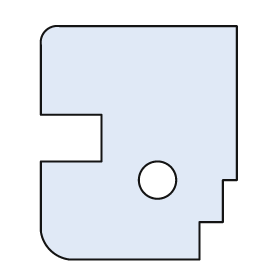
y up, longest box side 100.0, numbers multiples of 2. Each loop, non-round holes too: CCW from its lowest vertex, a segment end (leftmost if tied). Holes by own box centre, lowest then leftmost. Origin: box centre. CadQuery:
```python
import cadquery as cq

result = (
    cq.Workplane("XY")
    .moveTo(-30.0, -50.0)
    .lineTo(26.0, -50.0)
    .lineTo(26.0, -34.0)
    .lineTo(36.0, -34.0)
    .lineTo(36.0, -16.0)
    .lineTo(42.0, -16.0)
    .lineTo(42.0, 50.0)
    .lineTo(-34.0, 50.0)
    .threePointArc((-40.0, 48.0), (-42.0, 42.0))
    .lineTo(-42.0, 12.0)
    .lineTo(-16.0, 12.0)
    .lineTo(-16.0, -8.0)
    .lineTo(-42.0, -8.0)
    .lineTo(-42.0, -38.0)
    .threePointArc((-38.0, -46.0), (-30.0, -50.0))
    .close()
    .moveTo(8.0, -16.0)
    .circle(8.0)
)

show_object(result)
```